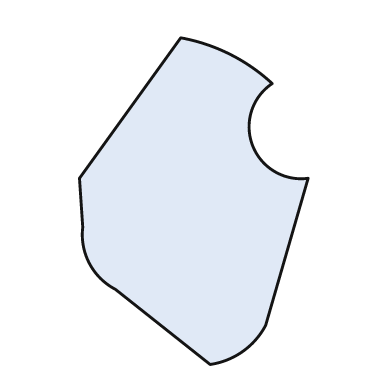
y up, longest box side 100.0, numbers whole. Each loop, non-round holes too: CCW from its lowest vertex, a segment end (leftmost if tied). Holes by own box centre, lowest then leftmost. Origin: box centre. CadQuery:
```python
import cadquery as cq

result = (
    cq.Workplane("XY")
    .moveTo(5.0, -50.0)
    .threePointArc((15.0, -46.0), (22.0, -38.0))
    .lineTo(35.0, 7.0)
    .threePointArc((18.0, 17.0), (24.0, 36.0))
    .threePointArc((11.0, 45.0), (-4.0, 50.0))
    .lineTo(-35.0, 7.0)
    .lineTo(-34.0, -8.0)
    .threePointArc((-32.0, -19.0), (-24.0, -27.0))
    .close()
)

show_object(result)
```